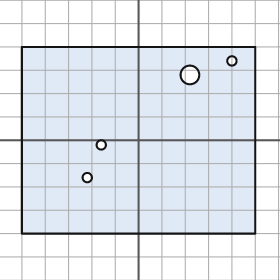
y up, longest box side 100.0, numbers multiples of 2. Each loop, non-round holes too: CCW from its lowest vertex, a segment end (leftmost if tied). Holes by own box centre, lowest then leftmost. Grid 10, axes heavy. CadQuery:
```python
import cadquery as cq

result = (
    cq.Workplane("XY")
    .moveTo(-50.0, -40.0)
    .lineTo(50.0, -40.0)
    .lineTo(50.0, 40.0)
    .lineTo(-50.0, 40.0)
    .close()
    .moveTo(-22.0, -16.0)
    .circle(2.0)
    .moveTo(-16.0, -2.0)
    .circle(2.0)
    .moveTo(22.0, 28.0)
    .circle(4.0)
    .moveTo(40.0, 34.0)
    .circle(2.0)
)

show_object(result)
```